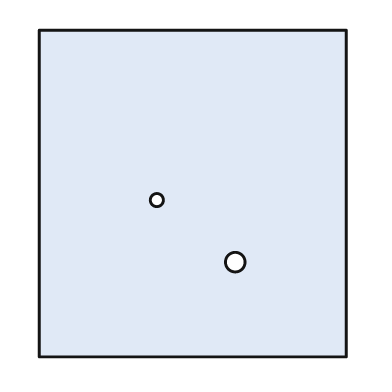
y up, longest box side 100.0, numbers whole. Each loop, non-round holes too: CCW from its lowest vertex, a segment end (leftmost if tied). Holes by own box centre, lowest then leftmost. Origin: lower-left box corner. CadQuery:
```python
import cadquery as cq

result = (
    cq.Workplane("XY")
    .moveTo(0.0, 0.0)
    .lineTo(94.0, 0.0)
    .lineTo(94.0, 100.0)
    .lineTo(0.0, 100.0)
    .close()
    .moveTo(60.0, 29.0)
    .circle(3.0)
    .moveTo(36.0, 48.0)
    .circle(2.0)
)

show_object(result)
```